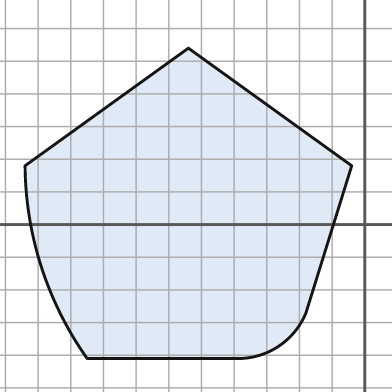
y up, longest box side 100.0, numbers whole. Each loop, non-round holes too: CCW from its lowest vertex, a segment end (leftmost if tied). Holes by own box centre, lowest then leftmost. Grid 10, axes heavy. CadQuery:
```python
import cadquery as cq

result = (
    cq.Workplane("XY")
    .moveTo(-85.0, -41.0)
    .lineTo(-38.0, -41.0)
    .threePointArc((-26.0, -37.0), (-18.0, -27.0))
    .lineTo(-4.0, 18.0)
    .lineTo(-54.0, 54.0)
    .lineTo(-104.0, 18.0)
    .threePointArc((-99.0, -13.0), (-85.0, -41.0))
    .close()
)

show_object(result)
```